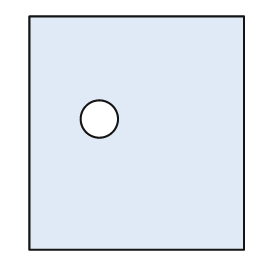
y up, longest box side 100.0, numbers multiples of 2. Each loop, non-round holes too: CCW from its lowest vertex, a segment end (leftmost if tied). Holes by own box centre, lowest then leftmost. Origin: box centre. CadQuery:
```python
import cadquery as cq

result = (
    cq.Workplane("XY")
    .moveTo(-46.0, -50.0)
    .lineTo(46.0, -50.0)
    .lineTo(46.0, 50.0)
    .lineTo(-46.0, 50.0)
    .close()
    .moveTo(-16.0, 6.0)
    .circle(8.0)
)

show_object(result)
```